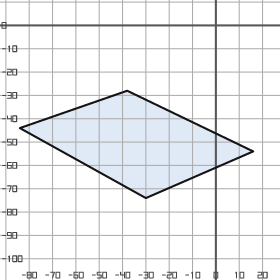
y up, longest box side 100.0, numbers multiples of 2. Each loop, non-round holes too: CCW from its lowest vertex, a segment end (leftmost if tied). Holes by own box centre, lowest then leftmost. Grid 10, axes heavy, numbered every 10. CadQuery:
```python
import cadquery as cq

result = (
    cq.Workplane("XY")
    .moveTo(-30.0, -74.0)
    .lineTo(16.0, -54.0)
    .lineTo(-38.0, -28.0)
    .lineTo(-84.0, -44.0)
    .close()
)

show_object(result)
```